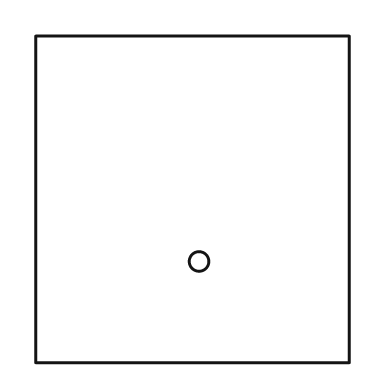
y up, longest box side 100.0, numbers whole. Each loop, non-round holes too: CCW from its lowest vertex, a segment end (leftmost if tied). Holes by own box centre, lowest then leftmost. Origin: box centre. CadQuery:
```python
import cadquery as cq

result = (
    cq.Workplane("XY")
    .moveTo(-48.0, -50.0)
    .lineTo(48.0, -50.0)
    .lineTo(48.0, 50.0)
    .lineTo(-48.0, 50.0)
    .close()
    .moveTo(2.0, -19.0)
    .circle(3.0)
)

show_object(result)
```